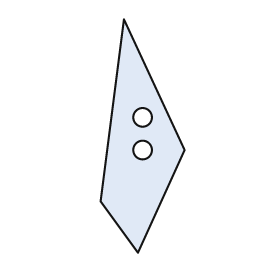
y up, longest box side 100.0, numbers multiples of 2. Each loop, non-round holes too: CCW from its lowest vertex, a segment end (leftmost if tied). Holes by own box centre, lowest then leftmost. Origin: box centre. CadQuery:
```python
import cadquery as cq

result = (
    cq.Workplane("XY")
    .moveTo(-2.0, -50.0)
    .lineTo(18.0, -6.0)
    .lineTo(-8.0, 50.0)
    .lineTo(-18.0, -28.0)
    .close()
    .moveTo(0.0, -6.0)
    .circle(4.0)
    .moveTo(0.0, 8.0)
    .circle(4.0)
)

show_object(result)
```